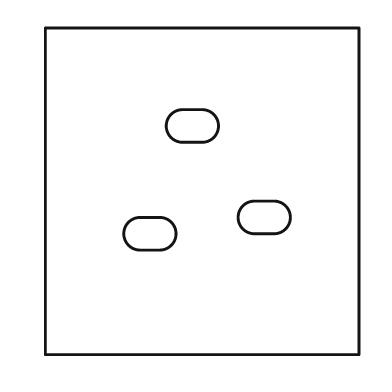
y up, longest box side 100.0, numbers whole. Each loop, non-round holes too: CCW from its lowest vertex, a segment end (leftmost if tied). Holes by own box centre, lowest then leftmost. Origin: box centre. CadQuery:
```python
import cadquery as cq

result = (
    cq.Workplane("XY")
    .moveTo(-48.0, -50.0)
    .lineTo(48.0, -50.0)
    .lineTo(48.0, 50.0)
    .lineTo(-48.0, 50.0)
    .close()
    .moveTo(-19.0, -18.0)
    .lineTo(-13.0, -18.0)
    .threePointArc((-8.0, -13.0), (-13.0, -8.0))
    .lineTo(-19.0, -8.0)
    .threePointArc((-24.0, -13.0), (-19.0, -18.0))
    .close()
    .moveTo(16.0, -13.0)
    .lineTo(22.0, -13.0)
    .threePointArc((27.0, -8.0), (22.0, -3.0))
    .lineTo(16.0, -3.0)
    .threePointArc((11.0, -8.0), (16.0, -13.0))
    .close()
    .moveTo(-6.0, 15.0)
    .lineTo(0.0, 15.0)
    .threePointArc((5.0, 20.0), (0.0, 25.0))
    .lineTo(-6.0, 25.0)
    .threePointArc((-11.0, 20.0), (-6.0, 15.0))
    .close()
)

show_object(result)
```